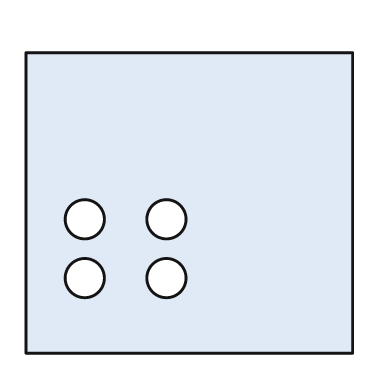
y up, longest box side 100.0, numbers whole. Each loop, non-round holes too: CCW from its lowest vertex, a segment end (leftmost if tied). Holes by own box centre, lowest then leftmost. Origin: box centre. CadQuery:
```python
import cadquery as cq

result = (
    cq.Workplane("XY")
    .moveTo(-50.0, -46.0)
    .lineTo(50.0, -46.0)
    .lineTo(50.0, 46.0)
    .lineTo(-50.0, 46.0)
    .close()
    .moveTo(-32.0, -23.0)
    .circle(6.0)
    .moveTo(-7.0, -23.0)
    .circle(6.0)
    .moveTo(-32.0, -5.0)
    .circle(6.0)
    .moveTo(-7.0, -5.0)
    .circle(6.0)
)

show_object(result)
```